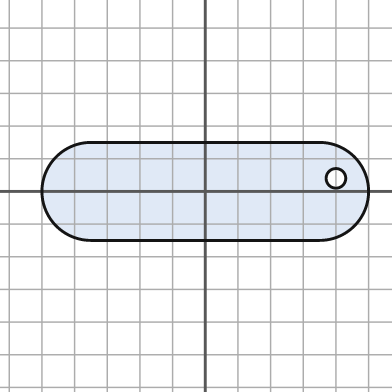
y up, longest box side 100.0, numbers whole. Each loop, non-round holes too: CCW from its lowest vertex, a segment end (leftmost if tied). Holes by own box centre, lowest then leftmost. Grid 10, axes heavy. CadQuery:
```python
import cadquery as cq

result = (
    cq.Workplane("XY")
    .moveTo(-35.0, -15.0)
    .lineTo(35.0, -15.0)
    .threePointArc((50.0, 0.0), (35.0, 15.0))
    .lineTo(-35.0, 15.0)
    .threePointArc((-50.0, 0.0), (-35.0, -15.0))
    .close()
    .moveTo(40.0, 4.0)
    .circle(3.0)
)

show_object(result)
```